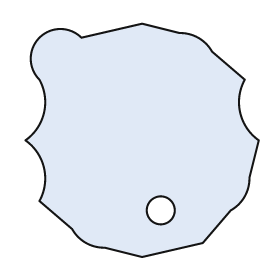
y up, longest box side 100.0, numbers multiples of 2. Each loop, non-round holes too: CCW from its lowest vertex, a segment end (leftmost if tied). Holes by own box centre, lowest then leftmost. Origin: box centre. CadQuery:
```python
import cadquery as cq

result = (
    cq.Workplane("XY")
    .moveTo(0.0, -50.0)
    .lineTo(26.0, -44.0)
    .lineTo(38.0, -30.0)
    .threePointArc((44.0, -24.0), (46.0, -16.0))
    .lineTo(50.0, 0.0)
    .threePointArc((42.0, 12.0), (44.0, 26.0))
    .lineTo(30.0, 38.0)
    .threePointArc((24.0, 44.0), (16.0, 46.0))
    .lineTo(0.0, 50.0)
    .lineTo(-26.0, 44.0)
    .threePointArc((-44.0, 44.0), (-44.0, 26.0))
    .threePointArc((-42.0, 12.0), (-50.0, 0.0))
    .threePointArc((-42.0, -12.0), (-44.0, -26.0))
    .lineTo(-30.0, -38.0)
    .threePointArc((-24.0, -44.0), (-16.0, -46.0))
    .close()
    .moveTo(8.0, -30.0)
    .circle(6.0)
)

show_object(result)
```